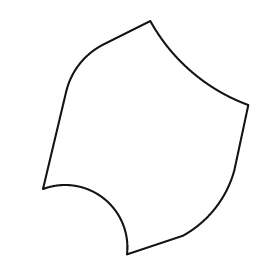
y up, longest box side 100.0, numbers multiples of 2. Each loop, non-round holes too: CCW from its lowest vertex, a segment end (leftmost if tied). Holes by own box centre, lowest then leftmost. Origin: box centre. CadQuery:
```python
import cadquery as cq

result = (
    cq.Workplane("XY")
    .moveTo(-8.0, -50.0)
    .lineTo(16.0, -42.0)
    .threePointArc((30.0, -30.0), (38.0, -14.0))
    .lineTo(44.0, 14.0)
    .threePointArc((20.0, 28.0), (2.0, 50.0))
    .lineTo(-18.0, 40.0)
    .threePointArc((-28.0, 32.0), (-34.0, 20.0))
    .lineTo(-44.0, -22.0)
    .threePointArc((-18.0, -26.0), (-8.0, -50.0))
    .close()
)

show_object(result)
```